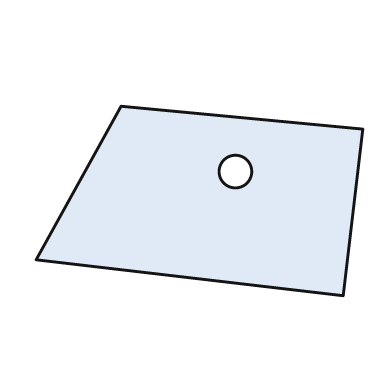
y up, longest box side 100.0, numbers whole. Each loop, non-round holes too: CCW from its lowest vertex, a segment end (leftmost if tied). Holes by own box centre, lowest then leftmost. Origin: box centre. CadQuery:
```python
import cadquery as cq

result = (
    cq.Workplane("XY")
    .moveTo(44.0, -29.0)
    .lineTo(50.0, 22.0)
    .lineTo(-24.0, 29.0)
    .lineTo(-50.0, -18.0)
    .close()
    .moveTo(11.0, 9.0)
    .circle(5.0)
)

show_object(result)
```